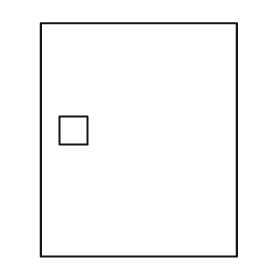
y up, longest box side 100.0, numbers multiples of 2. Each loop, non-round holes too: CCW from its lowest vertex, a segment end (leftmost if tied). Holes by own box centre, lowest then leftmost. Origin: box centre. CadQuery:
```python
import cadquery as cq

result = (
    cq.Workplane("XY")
    .moveTo(-42.0, -50.0)
    .lineTo(42.0, -50.0)
    .lineTo(42.0, 50.0)
    .lineTo(-42.0, 50.0)
    .close()
    .moveTo(-34.0, -2.0)
    .lineTo(-22.0, -2.0)
    .lineTo(-22.0, 10.0)
    .lineTo(-34.0, 10.0)
    .close()
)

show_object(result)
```